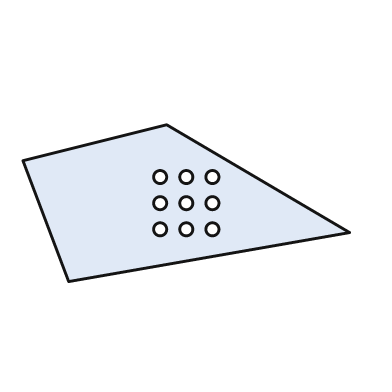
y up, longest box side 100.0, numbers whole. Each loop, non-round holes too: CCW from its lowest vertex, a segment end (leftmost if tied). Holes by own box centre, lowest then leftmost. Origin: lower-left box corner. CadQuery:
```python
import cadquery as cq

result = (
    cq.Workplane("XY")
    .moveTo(14.0, 0.0)
    .lineTo(100.0, 15.0)
    .lineTo(44.0, 48.0)
    .lineTo(0.0, 37.0)
    .close()
    .moveTo(42.0, 16.0)
    .circle(2.0)
    .moveTo(50.0, 16.0)
    .circle(2.0)
    .moveTo(58.0, 16.0)
    .circle(2.0)
    .moveTo(42.0, 24.0)
    .circle(2.0)
    .moveTo(50.0, 24.0)
    .circle(2.0)
    .moveTo(58.0, 24.0)
    .circle(2.0)
    .moveTo(42.0, 32.0)
    .circle(2.0)
    .moveTo(50.0, 32.0)
    .circle(2.0)
    .moveTo(58.0, 32.0)
    .circle(2.0)
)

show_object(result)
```